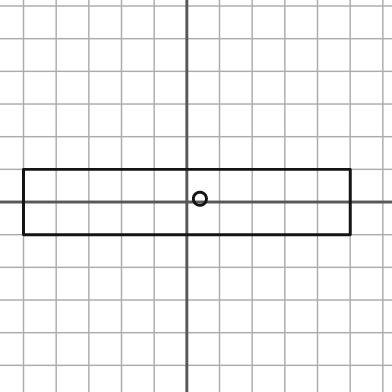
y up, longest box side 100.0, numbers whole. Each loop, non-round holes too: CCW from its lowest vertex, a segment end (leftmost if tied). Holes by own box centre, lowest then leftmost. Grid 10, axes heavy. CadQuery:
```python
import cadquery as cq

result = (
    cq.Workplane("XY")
    .moveTo(-50.0, -10.0)
    .lineTo(50.0, -10.0)
    .lineTo(50.0, 10.0)
    .lineTo(-50.0, 10.0)
    .close()
    .moveTo(4.0, 1.0)
    .circle(2.0)
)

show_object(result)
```